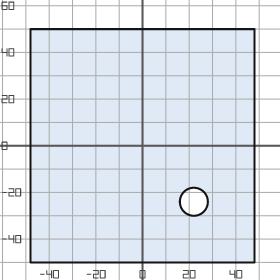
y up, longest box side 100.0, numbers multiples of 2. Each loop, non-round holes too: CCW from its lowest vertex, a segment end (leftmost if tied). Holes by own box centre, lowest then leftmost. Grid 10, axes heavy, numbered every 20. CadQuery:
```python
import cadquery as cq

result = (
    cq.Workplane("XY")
    .moveTo(-48.0, -50.0)
    .lineTo(48.0, -50.0)
    .lineTo(48.0, 50.0)
    .lineTo(-48.0, 50.0)
    .close()
    .moveTo(22.0, -24.0)
    .circle(6.0)
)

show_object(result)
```